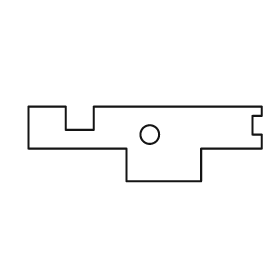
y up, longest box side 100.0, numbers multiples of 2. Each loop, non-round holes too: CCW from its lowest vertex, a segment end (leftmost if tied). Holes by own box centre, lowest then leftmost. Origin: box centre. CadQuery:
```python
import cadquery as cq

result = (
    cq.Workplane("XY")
    .moveTo(-8.0, -16.0)
    .lineTo(24.0, -16.0)
    .lineTo(24.0, -2.0)
    .lineTo(50.0, -2.0)
    .lineTo(50.0, 4.0)
    .lineTo(46.0, 4.0)
    .lineTo(46.0, 12.0)
    .lineTo(50.0, 12.0)
    .lineTo(50.0, 16.0)
    .lineTo(-22.0, 16.0)
    .lineTo(-22.0, 6.0)
    .lineTo(-34.0, 6.0)
    .lineTo(-34.0, 16.0)
    .lineTo(-50.0, 16.0)
    .lineTo(-50.0, -2.0)
    .lineTo(-8.0, -2.0)
    .close()
    .moveTo(2.0, 4.0)
    .circle(4.0)
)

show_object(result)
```